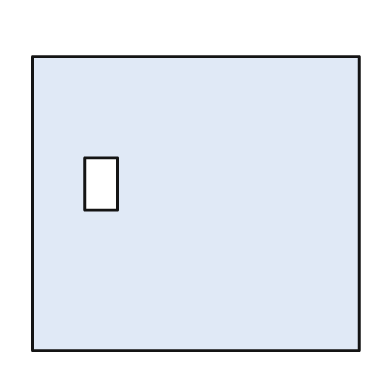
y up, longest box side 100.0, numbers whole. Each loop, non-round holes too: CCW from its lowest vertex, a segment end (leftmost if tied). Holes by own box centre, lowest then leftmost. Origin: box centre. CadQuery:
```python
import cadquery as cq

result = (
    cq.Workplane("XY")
    .moveTo(-50.0, -45.0)
    .lineTo(50.0, -45.0)
    .lineTo(50.0, 45.0)
    .lineTo(-50.0, 45.0)
    .close()
    .moveTo(-34.0, -2.0)
    .lineTo(-24.0, -2.0)
    .lineTo(-24.0, 14.0)
    .lineTo(-34.0, 14.0)
    .close()
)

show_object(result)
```